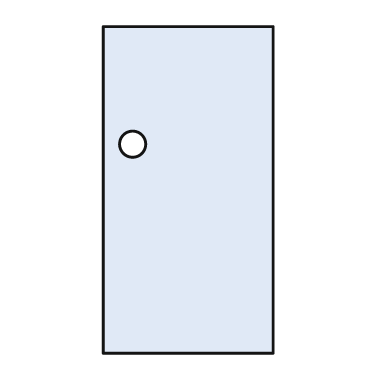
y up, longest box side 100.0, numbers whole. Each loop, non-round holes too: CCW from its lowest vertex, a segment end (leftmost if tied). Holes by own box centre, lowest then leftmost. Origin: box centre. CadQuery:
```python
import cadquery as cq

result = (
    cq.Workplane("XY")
    .moveTo(-26.0, -50.0)
    .lineTo(26.0, -50.0)
    .lineTo(26.0, 50.0)
    .lineTo(-26.0, 50.0)
    .close()
    .moveTo(-17.0, 14.0)
    .circle(4.0)
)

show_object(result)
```